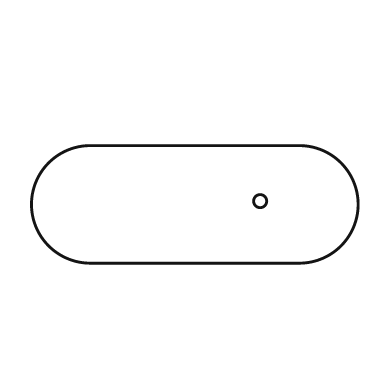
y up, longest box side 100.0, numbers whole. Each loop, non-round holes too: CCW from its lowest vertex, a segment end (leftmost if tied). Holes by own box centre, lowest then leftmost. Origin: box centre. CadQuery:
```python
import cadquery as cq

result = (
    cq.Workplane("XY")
    .moveTo(-32.0, -18.0)
    .lineTo(32.0, -18.0)
    .threePointArc((50.0, 0.0), (32.0, 18.0))
    .lineTo(-32.0, 18.0)
    .threePointArc((-50.0, 0.0), (-32.0, -18.0))
    .close()
    .moveTo(20.0, 1.0)
    .circle(2.0)
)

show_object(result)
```